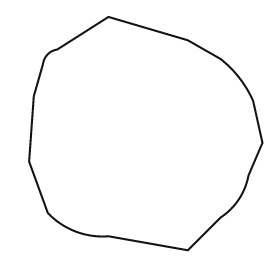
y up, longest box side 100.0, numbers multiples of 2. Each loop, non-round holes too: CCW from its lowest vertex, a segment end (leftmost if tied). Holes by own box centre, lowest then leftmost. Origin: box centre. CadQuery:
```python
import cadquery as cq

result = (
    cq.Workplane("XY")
    .moveTo(18.0, -50.0)
    .lineTo(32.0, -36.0)
    .threePointArc((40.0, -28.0), (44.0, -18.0))
    .lineTo(50.0, -4.0)
    .lineTo(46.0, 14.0)
    .threePointArc((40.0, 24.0), (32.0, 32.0))
    .lineTo(18.0, 40.0)
    .lineTo(-16.0, 50.0)
    .lineTo(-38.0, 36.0)
    .threePointArc((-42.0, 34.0), (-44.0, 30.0))
    .lineTo(-48.0, 16.0)
    .lineTo(-50.0, -12.0)
    .lineTo(-42.0, -34.0)
    .threePointArc((-30.0, -42.0), (-16.0, -44.0))
    .close()
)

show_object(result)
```